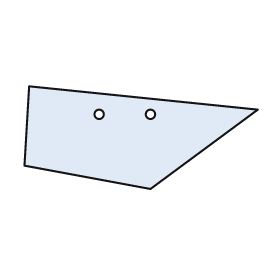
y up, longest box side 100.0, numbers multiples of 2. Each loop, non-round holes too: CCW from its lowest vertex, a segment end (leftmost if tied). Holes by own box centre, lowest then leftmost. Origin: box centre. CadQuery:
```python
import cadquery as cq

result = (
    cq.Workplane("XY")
    .moveTo(4.0, -22.0)
    .lineTo(50.0, 12.0)
    .lineTo(-48.0, 22.0)
    .lineTo(-50.0, -12.0)
    .close()
    .moveTo(-18.0, 10.0)
    .circle(2.0)
    .moveTo(4.0, 10.0)
    .circle(2.0)
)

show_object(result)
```